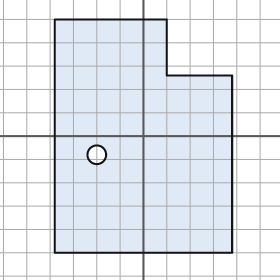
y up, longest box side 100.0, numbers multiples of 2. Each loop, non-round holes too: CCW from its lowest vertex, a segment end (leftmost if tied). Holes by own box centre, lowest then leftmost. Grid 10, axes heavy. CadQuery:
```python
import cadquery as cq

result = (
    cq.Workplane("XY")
    .moveTo(-38.0, -50.0)
    .lineTo(38.0, -50.0)
    .lineTo(38.0, 26.0)
    .lineTo(10.0, 26.0)
    .lineTo(10.0, 50.0)
    .lineTo(-38.0, 50.0)
    .close()
    .moveTo(-20.0, -8.0)
    .circle(4.0)
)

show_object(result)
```